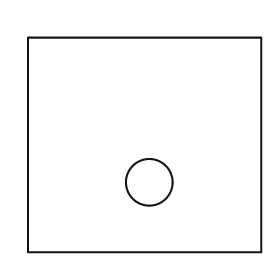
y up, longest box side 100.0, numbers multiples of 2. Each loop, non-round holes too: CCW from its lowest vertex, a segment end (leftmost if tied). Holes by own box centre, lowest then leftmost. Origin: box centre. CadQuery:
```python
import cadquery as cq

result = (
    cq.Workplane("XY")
    .moveTo(-50.0, -46.0)
    .lineTo(50.0, -46.0)
    .lineTo(50.0, 46.0)
    .lineTo(-50.0, 46.0)
    .close()
    .moveTo(2.0, -16.0)
    .circle(10.0)
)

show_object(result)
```